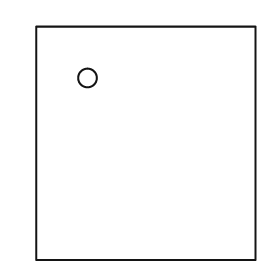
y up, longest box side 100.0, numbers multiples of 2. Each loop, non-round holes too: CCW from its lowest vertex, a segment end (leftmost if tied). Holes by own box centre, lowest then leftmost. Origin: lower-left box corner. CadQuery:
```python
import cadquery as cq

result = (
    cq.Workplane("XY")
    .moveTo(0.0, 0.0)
    .lineTo(94.0, 0.0)
    .lineTo(94.0, 100.0)
    .lineTo(0.0, 100.0)
    .close()
    .moveTo(22.0, 78.0)
    .circle(4.0)
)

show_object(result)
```